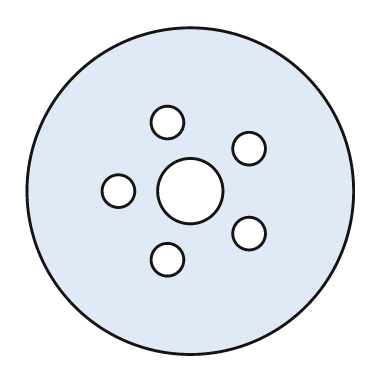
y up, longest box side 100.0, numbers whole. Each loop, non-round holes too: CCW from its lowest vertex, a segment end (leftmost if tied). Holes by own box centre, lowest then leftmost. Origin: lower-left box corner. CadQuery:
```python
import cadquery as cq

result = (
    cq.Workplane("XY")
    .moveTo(50.0, 50.0)
    .circle(50.0)
    .moveTo(43.0, 29.0)
    .circle(5.0)
    .moveTo(68.0, 37.0)
    .circle(5.0)
    .moveTo(28.0, 50.0)
    .circle(5.0)
    .moveTo(50.0, 50.0)
    .circle(10.0)
    .moveTo(68.0, 63.0)
    .circle(5.0)
    .moveTo(43.0, 71.0)
    .circle(5.0)
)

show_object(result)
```